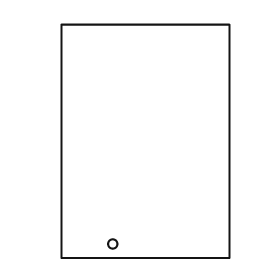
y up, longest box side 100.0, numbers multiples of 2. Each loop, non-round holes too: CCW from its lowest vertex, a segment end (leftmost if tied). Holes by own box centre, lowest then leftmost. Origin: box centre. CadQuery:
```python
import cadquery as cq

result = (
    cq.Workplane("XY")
    .moveTo(-36.0, -50.0)
    .lineTo(36.0, -50.0)
    .lineTo(36.0, 50.0)
    .lineTo(-36.0, 50.0)
    .close()
    .moveTo(-14.0, -44.0)
    .circle(2.0)
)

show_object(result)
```